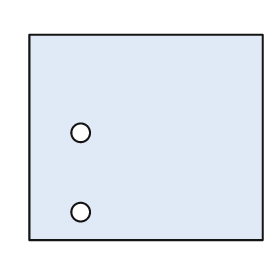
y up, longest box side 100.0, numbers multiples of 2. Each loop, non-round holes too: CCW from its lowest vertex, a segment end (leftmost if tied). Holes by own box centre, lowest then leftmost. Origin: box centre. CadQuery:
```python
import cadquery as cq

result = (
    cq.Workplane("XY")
    .moveTo(-50.0, -44.0)
    .lineTo(50.0, -44.0)
    .lineTo(50.0, 44.0)
    .lineTo(-50.0, 44.0)
    .close()
    .moveTo(-28.0, -32.0)
    .circle(4.0)
    .moveTo(-28.0, 2.0)
    .circle(4.0)
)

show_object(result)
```